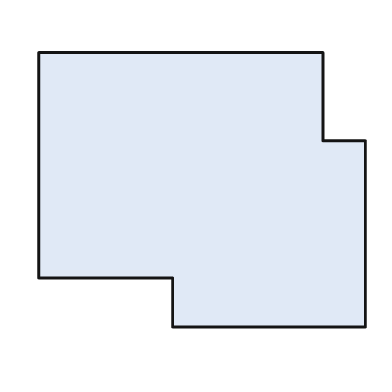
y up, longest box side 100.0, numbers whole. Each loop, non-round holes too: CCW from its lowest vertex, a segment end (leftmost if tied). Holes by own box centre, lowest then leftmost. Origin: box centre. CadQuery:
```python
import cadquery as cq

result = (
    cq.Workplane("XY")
    .moveTo(-9.0, -42.0)
    .lineTo(50.0, -42.0)
    .lineTo(50.0, 15.0)
    .lineTo(37.0, 15.0)
    .lineTo(37.0, 42.0)
    .lineTo(-50.0, 42.0)
    .lineTo(-50.0, -27.0)
    .lineTo(-9.0, -27.0)
    .close()
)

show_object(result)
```